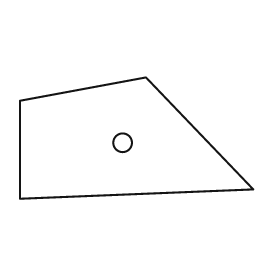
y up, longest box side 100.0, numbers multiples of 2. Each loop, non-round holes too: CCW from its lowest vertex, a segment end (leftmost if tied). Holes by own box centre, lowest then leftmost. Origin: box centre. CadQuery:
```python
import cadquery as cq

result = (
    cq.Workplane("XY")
    .moveTo(-50.0, -26.0)
    .lineTo(50.0, -22.0)
    .lineTo(4.0, 26.0)
    .lineTo(-50.0, 16.0)
    .close()
    .moveTo(-6.0, -2.0)
    .circle(4.0)
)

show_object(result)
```